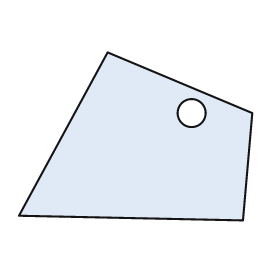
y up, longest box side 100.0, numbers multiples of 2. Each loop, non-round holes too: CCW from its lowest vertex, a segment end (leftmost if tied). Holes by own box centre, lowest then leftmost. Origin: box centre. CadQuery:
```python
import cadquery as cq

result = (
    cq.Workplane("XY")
    .moveTo(46.0, -36.0)
    .lineTo(50.0, 10.0)
    .lineTo(-12.0, 36.0)
    .lineTo(-50.0, -34.0)
    .close()
    .moveTo(24.0, 10.0)
    .circle(6.0)
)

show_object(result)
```